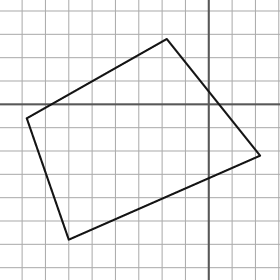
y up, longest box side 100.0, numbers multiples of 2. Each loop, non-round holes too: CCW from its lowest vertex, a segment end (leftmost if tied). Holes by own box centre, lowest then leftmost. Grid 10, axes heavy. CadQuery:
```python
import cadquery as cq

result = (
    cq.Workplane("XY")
    .moveTo(-60.0, -58.0)
    .lineTo(22.0, -22.0)
    .lineTo(-18.0, 28.0)
    .lineTo(-78.0, -6.0)
    .close()
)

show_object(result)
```